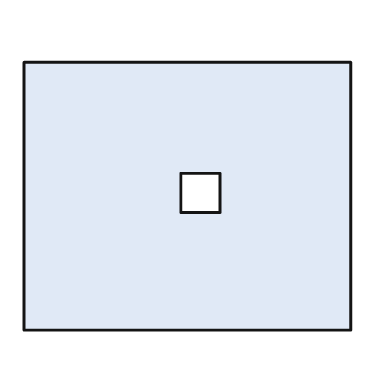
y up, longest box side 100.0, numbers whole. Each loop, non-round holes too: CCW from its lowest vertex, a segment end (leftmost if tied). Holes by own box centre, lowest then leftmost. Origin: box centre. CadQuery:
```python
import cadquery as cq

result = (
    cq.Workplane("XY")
    .moveTo(-50.0, -41.0)
    .lineTo(50.0, -41.0)
    .lineTo(50.0, 41.0)
    .lineTo(-50.0, 41.0)
    .close()
    .moveTo(-2.0, -5.0)
    .lineTo(10.0, -5.0)
    .lineTo(10.0, 7.0)
    .lineTo(-2.0, 7.0)
    .close()
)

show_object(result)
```